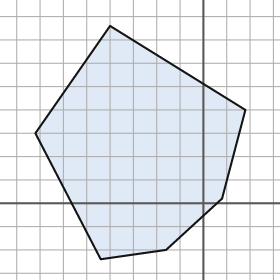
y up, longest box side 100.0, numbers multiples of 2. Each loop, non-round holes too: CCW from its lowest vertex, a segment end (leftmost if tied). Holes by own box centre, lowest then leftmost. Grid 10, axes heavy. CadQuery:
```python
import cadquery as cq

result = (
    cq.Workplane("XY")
    .moveTo(-44.0, -24.0)
    .lineTo(-16.0, -20.0)
    .lineTo(8.0, 2.0)
    .lineTo(18.0, 40.0)
    .lineTo(-40.0, 76.0)
    .lineTo(-72.0, 30.0)
    .close()
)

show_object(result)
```